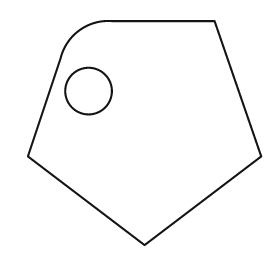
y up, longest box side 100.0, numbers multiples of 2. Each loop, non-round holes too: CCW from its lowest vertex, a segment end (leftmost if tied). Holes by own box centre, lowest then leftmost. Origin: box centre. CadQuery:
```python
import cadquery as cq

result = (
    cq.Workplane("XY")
    .moveTo(0.0, -48.0)
    .lineTo(50.0, -10.0)
    .lineTo(30.0, 48.0)
    .lineTo(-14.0, 48.0)
    .threePointArc((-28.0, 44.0), (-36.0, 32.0))
    .lineTo(-50.0, -10.0)
    .close()
    .moveTo(-24.0, 18.0)
    .circle(10.0)
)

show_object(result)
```